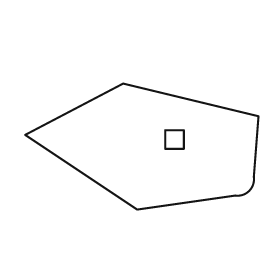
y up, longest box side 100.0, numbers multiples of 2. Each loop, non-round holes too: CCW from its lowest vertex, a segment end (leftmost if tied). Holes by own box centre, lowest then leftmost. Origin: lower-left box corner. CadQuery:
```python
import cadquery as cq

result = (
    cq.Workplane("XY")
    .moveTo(48.0, 0.0)
    .lineTo(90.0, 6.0)
    .threePointArc((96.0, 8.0), (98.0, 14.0))
    .lineTo(100.0, 40.0)
    .lineTo(42.0, 54.0)
    .lineTo(0.0, 32.0)
    .close()
    .moveTo(60.0, 26.0)
    .lineTo(68.0, 26.0)
    .lineTo(68.0, 34.0)
    .lineTo(60.0, 34.0)
    .close()
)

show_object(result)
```